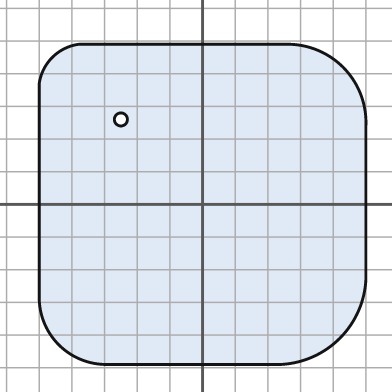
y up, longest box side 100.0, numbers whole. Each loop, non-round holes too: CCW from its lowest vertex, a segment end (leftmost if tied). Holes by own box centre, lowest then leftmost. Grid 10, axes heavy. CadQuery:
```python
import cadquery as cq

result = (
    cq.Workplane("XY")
    .moveTo(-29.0, -49.0)
    .lineTo(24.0, -49.0)
    .threePointArc((42.0, -41.0), (50.0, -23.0))
    .lineTo(50.0, 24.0)
    .threePointArc((43.0, 42.0), (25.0, 49.0))
    .lineTo(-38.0, 49.0)
    .threePointArc((-46.0, 45.0), (-50.0, 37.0))
    .lineTo(-50.0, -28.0)
    .threePointArc((-44.0, -43.0), (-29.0, -49.0))
    .close()
    .moveTo(-25.0, 26.0)
    .circle(2.0)
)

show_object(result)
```